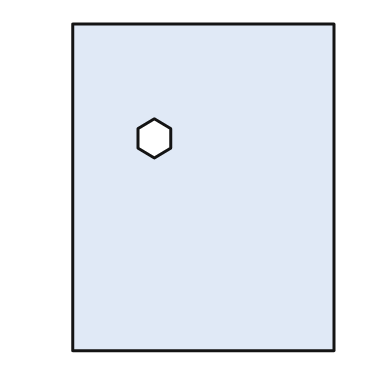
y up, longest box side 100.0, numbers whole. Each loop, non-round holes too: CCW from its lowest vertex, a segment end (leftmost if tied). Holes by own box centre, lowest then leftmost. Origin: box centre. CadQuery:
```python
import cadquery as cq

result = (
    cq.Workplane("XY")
    .moveTo(-40.0, -50.0)
    .lineTo(40.0, -50.0)
    .lineTo(40.0, 50.0)
    .lineTo(-40.0, 50.0)
    .close()
    .moveTo(-15.0, 9.0)
    .lineTo(-10.0, 12.0)
    .lineTo(-10.0, 18.0)
    .lineTo(-15.0, 21.0)
    .lineTo(-20.0, 18.0)
    .lineTo(-20.0, 12.0)
    .close()
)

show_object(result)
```